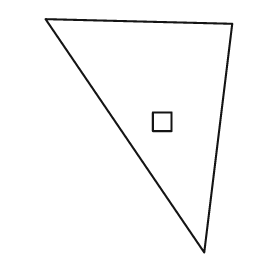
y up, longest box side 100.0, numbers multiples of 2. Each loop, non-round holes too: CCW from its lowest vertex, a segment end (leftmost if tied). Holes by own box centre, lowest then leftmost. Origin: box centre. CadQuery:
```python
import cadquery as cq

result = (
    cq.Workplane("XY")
    .moveTo(28.0, -50.0)
    .lineTo(40.0, 48.0)
    .lineTo(-40.0, 50.0)
    .close()
    .moveTo(6.0, 2.0)
    .lineTo(14.0, 2.0)
    .lineTo(14.0, 10.0)
    .lineTo(6.0, 10.0)
    .close()
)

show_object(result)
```